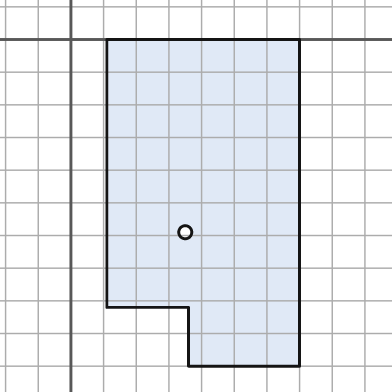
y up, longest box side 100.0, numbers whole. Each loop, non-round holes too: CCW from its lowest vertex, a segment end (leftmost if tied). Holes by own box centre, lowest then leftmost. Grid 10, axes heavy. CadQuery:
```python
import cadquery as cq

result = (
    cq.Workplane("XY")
    .moveTo(36.0, -100.0)
    .lineTo(70.0, -100.0)
    .lineTo(70.0, 0.0)
    .lineTo(11.0, 0.0)
    .lineTo(11.0, -82.0)
    .lineTo(36.0, -82.0)
    .close()
    .moveTo(35.0, -59.0)
    .circle(2.0)
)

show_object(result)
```